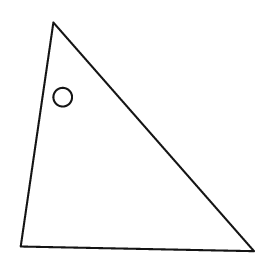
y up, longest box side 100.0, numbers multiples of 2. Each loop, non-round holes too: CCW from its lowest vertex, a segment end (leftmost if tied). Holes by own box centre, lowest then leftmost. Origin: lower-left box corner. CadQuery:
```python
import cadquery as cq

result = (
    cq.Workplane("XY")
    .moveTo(100.0, 0.0)
    .lineTo(14.0, 98.0)
    .lineTo(0.0, 2.0)
    .close()
    .moveTo(18.0, 66.0)
    .circle(4.0)
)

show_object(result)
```